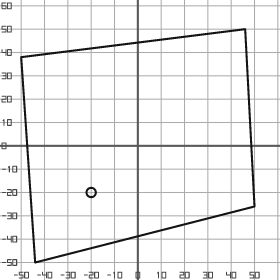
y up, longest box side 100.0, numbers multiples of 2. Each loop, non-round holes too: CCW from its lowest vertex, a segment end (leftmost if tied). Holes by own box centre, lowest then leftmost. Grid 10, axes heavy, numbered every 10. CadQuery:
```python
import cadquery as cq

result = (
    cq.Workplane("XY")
    .moveTo(-44.0, -50.0)
    .lineTo(50.0, -26.0)
    .lineTo(46.0, 50.0)
    .lineTo(-50.0, 38.0)
    .close()
    .moveTo(-20.0, -20.0)
    .circle(2.0)
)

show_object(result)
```